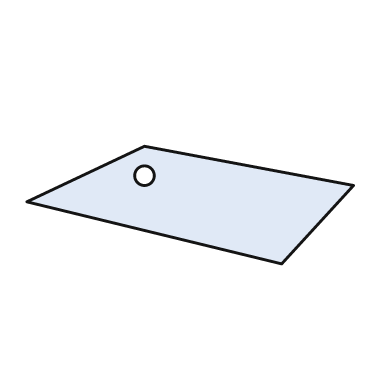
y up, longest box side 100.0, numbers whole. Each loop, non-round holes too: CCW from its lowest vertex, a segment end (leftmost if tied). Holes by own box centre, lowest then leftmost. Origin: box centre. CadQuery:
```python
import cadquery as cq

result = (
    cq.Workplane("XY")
    .moveTo(28.0, -18.0)
    .lineTo(50.0, 6.0)
    .lineTo(-14.0, 18.0)
    .lineTo(-50.0, 1.0)
    .close()
    .moveTo(-14.0, 9.0)
    .circle(3.0)
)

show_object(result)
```